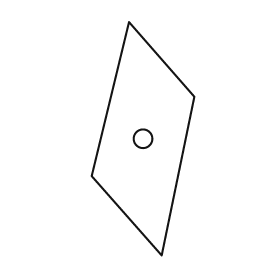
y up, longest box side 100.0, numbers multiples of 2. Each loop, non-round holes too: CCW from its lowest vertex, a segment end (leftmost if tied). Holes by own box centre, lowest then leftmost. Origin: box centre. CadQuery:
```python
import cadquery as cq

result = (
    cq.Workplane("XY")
    .moveTo(8.0, -50.0)
    .lineTo(22.0, 18.0)
    .lineTo(-6.0, 50.0)
    .lineTo(-22.0, -16.0)
    .close()
    .moveTo(0.0, 0.0)
    .circle(4.0)
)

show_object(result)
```